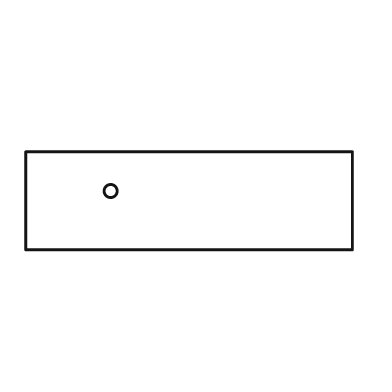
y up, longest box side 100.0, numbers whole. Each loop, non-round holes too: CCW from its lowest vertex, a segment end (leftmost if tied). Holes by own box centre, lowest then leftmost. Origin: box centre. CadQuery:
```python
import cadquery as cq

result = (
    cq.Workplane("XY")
    .moveTo(-50.0, -15.0)
    .lineTo(50.0, -15.0)
    .lineTo(50.0, 15.0)
    .lineTo(-50.0, 15.0)
    .close()
    .moveTo(-24.0, 3.0)
    .circle(2.0)
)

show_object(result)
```